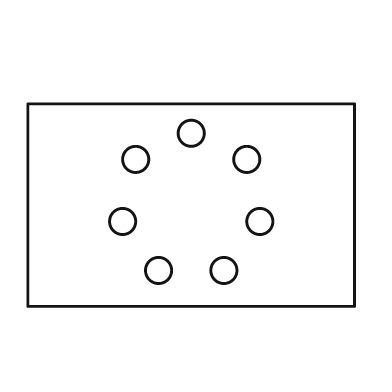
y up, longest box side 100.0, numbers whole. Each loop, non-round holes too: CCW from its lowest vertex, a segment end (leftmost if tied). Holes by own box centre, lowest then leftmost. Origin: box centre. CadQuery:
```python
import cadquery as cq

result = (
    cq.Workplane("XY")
    .moveTo(-50.0, -31.0)
    .lineTo(50.0, -31.0)
    .lineTo(50.0, 31.0)
    .lineTo(-50.0, 31.0)
    .close()
    .moveTo(-10.0, -20.0)
    .circle(4.0)
    .moveTo(10.0, -20.0)
    .circle(4.0)
    .moveTo(-21.0, -5.0)
    .circle(4.0)
    .moveTo(21.0, -5.0)
    .circle(4.0)
    .moveTo(-17.0, 14.0)
    .circle(4.0)
    .moveTo(17.0, 14.0)
    .circle(4.0)
    .moveTo(0.0, 22.0)
    .circle(4.0)
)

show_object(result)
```